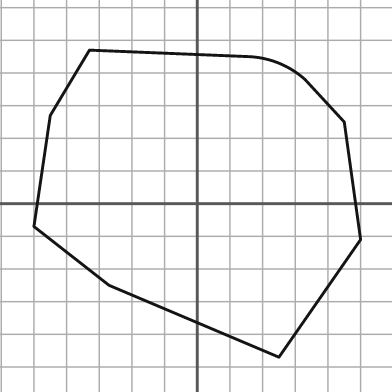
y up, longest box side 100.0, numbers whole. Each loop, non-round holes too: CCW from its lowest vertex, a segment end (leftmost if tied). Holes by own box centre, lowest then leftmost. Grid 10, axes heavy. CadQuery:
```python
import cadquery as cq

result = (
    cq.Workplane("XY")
    .moveTo(25.0, -47.0)
    .lineTo(50.0, -11.0)
    .lineTo(45.0, 25.0)
    .lineTo(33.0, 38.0)
    .threePointArc((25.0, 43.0), (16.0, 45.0))
    .lineTo(-33.0, 47.0)
    .lineTo(-45.0, 27.0)
    .lineTo(-50.0, -7.0)
    .lineTo(-27.0, -25.0)
    .close()
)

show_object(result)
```